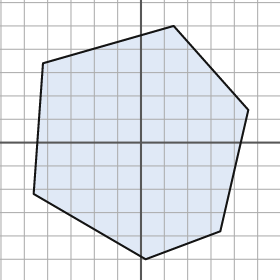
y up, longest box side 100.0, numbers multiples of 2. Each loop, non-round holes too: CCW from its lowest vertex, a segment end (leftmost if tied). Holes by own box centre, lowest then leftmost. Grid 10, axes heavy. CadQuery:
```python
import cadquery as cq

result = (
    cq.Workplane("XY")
    .moveTo(2.0, -50.0)
    .lineTo(34.0, -38.0)
    .lineTo(46.0, 14.0)
    .lineTo(14.0, 50.0)
    .lineTo(-42.0, 34.0)
    .lineTo(-46.0, -22.0)
    .close()
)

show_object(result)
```